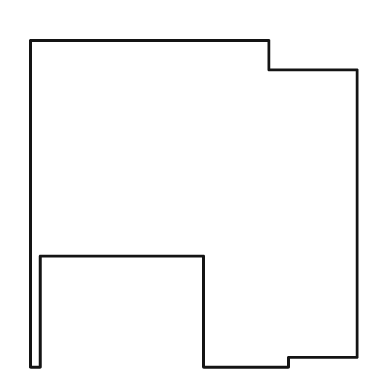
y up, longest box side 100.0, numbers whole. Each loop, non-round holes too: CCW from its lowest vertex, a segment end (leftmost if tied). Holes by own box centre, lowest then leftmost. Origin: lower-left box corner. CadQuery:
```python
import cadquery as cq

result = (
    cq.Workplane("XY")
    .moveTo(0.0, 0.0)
    .lineTo(3.0, 0.0)
    .lineTo(3.0, 34.0)
    .lineTo(53.0, 34.0)
    .lineTo(53.0, 0.0)
    .lineTo(79.0, 0.0)
    .lineTo(79.0, 3.0)
    .lineTo(100.0, 3.0)
    .lineTo(100.0, 91.0)
    .lineTo(73.0, 91.0)
    .lineTo(73.0, 100.0)
    .lineTo(0.0, 100.0)
    .close()
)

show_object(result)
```